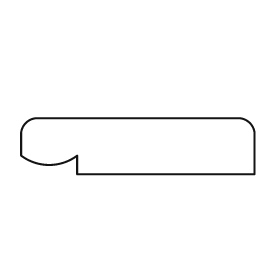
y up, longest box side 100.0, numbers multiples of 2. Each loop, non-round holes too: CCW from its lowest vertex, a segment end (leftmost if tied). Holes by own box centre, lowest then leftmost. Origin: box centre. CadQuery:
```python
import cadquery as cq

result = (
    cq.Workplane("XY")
    .moveTo(-26.0, -12.0)
    .lineTo(50.0, -12.0)
    .lineTo(50.0, 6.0)
    .threePointArc((48.0, 10.0), (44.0, 12.0))
    .lineTo(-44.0, 12.0)
    .threePointArc((-48.0, 10.0), (-50.0, 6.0))
    .lineTo(-50.0, -4.0)
    .threePointArc((-38.0, -8.0), (-26.0, -4.0))
    .close()
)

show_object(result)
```